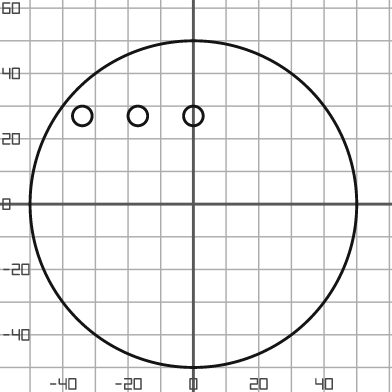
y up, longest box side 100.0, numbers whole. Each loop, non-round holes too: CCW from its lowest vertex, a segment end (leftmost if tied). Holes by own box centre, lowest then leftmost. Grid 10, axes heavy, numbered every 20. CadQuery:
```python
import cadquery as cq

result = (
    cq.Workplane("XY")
    .moveTo(0.0, 0.0)
    .circle(50.0)
    .moveTo(-34.0, 27.0)
    .circle(3.0)
    .moveTo(-17.0, 27.0)
    .circle(3.0)
    .moveTo(0.0, 27.0)
    .circle(3.0)
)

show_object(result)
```